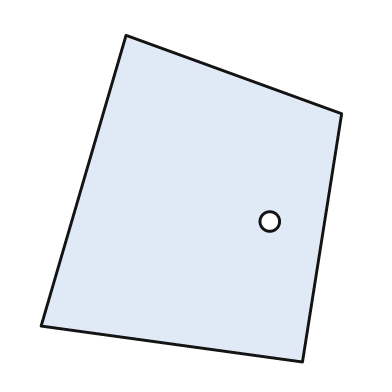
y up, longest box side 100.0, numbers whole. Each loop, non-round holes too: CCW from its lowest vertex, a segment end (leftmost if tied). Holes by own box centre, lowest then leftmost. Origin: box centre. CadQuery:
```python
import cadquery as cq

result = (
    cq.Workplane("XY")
    .moveTo(34.0, -50.0)
    .lineTo(46.0, 26.0)
    .lineTo(-20.0, 50.0)
    .lineTo(-46.0, -39.0)
    .close()
    .moveTo(24.0, -7.0)
    .circle(3.0)
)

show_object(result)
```